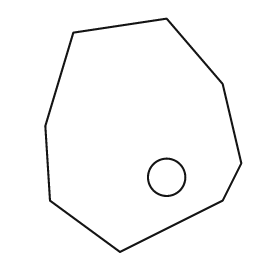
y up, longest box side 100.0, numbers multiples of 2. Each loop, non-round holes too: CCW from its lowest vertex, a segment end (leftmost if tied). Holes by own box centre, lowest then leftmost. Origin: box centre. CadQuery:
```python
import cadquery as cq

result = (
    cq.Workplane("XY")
    .moveTo(-10.0, -50.0)
    .lineTo(34.0, -28.0)
    .lineTo(42.0, -12.0)
    .lineTo(34.0, 22.0)
    .lineTo(10.0, 50.0)
    .lineTo(-30.0, 44.0)
    .lineTo(-42.0, 4.0)
    .lineTo(-40.0, -28.0)
    .close()
    .moveTo(10.0, -18.0)
    .circle(8.0)
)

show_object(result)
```